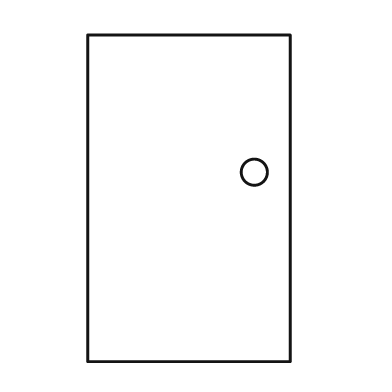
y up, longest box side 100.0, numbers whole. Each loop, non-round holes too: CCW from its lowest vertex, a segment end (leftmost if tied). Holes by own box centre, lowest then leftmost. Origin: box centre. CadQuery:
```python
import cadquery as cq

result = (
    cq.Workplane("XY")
    .moveTo(-31.0, -50.0)
    .lineTo(31.0, -50.0)
    .lineTo(31.0, 50.0)
    .lineTo(-31.0, 50.0)
    .close()
    .moveTo(20.0, 8.0)
    .circle(4.0)
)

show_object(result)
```